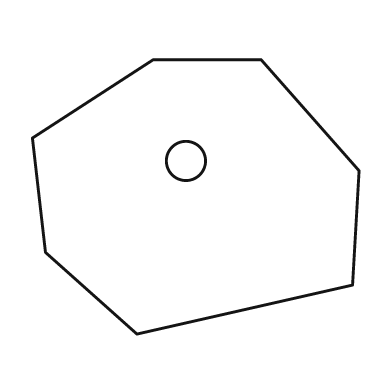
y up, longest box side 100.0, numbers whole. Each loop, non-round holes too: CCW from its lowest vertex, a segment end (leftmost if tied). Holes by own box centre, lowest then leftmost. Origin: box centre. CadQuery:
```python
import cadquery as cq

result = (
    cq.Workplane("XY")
    .moveTo(-18.0, -42.0)
    .lineTo(48.0, -27.0)
    .lineTo(50.0, 8.0)
    .lineTo(20.0, 42.0)
    .lineTo(-13.0, 42.0)
    .lineTo(-50.0, 18.0)
    .lineTo(-46.0, -17.0)
    .close()
    .moveTo(-3.0, 11.0)
    .circle(6.0)
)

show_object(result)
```